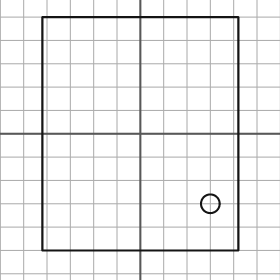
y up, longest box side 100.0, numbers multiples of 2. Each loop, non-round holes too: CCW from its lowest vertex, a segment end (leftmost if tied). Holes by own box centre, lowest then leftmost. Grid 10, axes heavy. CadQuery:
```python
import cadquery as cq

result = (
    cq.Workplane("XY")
    .moveTo(-42.0, -50.0)
    .lineTo(42.0, -50.0)
    .lineTo(42.0, 50.0)
    .lineTo(-42.0, 50.0)
    .close()
    .moveTo(30.0, -30.0)
    .circle(4.0)
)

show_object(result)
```